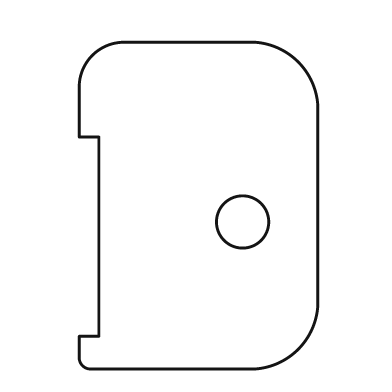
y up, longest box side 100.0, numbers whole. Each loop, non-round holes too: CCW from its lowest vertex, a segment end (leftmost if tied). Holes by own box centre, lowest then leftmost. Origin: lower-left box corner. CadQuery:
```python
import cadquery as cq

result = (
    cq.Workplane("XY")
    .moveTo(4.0, 0.0)
    .lineTo(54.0, 0.0)
    .threePointArc((67.0, 6.0), (73.0, 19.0))
    .lineTo(73.0, 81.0)
    .threePointArc((67.0, 94.0), (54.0, 100.0))
    .lineTo(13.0, 100.0)
    .threePointArc((4.0, 96.0), (0.0, 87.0))
    .lineTo(0.0, 71.0)
    .lineTo(6.0, 71.0)
    .lineTo(6.0, 10.0)
    .lineTo(0.0, 10.0)
    .lineTo(0.0, 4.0)
    .threePointArc((1.0, 1.0), (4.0, 0.0))
    .close()
    .moveTo(50.0, 45.0)
    .circle(8.0)
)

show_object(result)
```